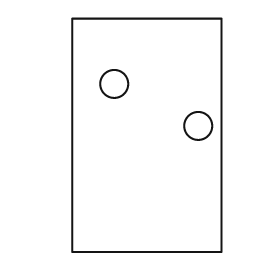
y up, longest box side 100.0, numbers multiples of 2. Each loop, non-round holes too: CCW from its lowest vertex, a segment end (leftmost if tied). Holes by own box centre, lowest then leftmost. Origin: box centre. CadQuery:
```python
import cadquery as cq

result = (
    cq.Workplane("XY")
    .moveTo(-32.0, -50.0)
    .lineTo(32.0, -50.0)
    .lineTo(32.0, 50.0)
    .lineTo(-32.0, 50.0)
    .close()
    .moveTo(22.0, 4.0)
    .circle(6.0)
    .moveTo(-14.0, 22.0)
    .circle(6.0)
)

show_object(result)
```